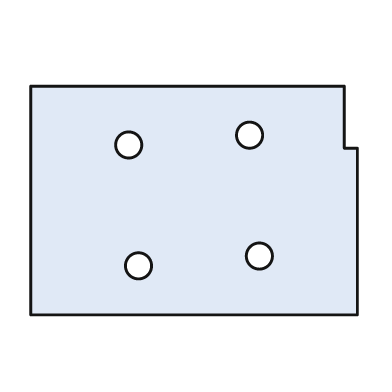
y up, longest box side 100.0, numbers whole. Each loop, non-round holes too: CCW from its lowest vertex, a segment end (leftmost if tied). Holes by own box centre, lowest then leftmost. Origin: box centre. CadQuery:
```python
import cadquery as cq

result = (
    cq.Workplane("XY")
    .moveTo(-50.0, -35.0)
    .lineTo(50.0, -35.0)
    .lineTo(50.0, 16.0)
    .lineTo(46.0, 16.0)
    .lineTo(46.0, 35.0)
    .lineTo(-50.0, 35.0)
    .close()
    .moveTo(-17.0, -20.0)
    .circle(4.0)
    .moveTo(20.0, -17.0)
    .circle(4.0)
    .moveTo(-20.0, 17.0)
    .circle(4.0)
    .moveTo(17.0, 20.0)
    .circle(4.0)
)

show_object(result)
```